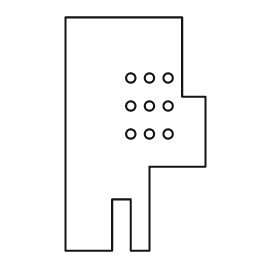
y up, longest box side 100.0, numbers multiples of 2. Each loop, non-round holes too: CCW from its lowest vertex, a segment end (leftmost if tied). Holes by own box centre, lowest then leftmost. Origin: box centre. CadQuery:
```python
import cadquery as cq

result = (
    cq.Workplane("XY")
    .moveTo(-30.0, -50.0)
    .lineTo(-10.0, -50.0)
    .lineTo(-10.0, -28.0)
    .lineTo(-2.0, -28.0)
    .lineTo(-2.0, -50.0)
    .lineTo(6.0, -50.0)
    .lineTo(6.0, -14.0)
    .lineTo(30.0, -14.0)
    .lineTo(30.0, 16.0)
    .lineTo(20.0, 16.0)
    .lineTo(20.0, 50.0)
    .lineTo(-30.0, 50.0)
    .close()
    .moveTo(-2.0, 0.0)
    .circle(2.0)
    .moveTo(6.0, 0.0)
    .circle(2.0)
    .moveTo(14.0, 0.0)
    .circle(2.0)
    .moveTo(-2.0, 12.0)
    .circle(2.0)
    .moveTo(6.0, 12.0)
    .circle(2.0)
    .moveTo(14.0, 12.0)
    .circle(2.0)
    .moveTo(-2.0, 24.0)
    .circle(2.0)
    .moveTo(6.0, 24.0)
    .circle(2.0)
    .moveTo(14.0, 24.0)
    .circle(2.0)
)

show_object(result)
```